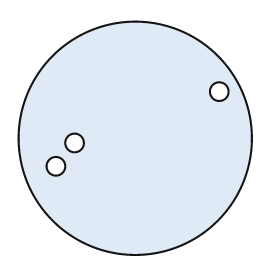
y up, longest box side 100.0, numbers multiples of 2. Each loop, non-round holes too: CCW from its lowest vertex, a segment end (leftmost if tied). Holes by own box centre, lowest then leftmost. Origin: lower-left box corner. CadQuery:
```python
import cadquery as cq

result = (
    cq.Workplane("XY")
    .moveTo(50.0, 50.0)
    .circle(50.0)
    .moveTo(16.0, 38.0)
    .circle(4.0)
    .moveTo(24.0, 48.0)
    .circle(4.0)
    .moveTo(86.0, 70.0)
    .circle(4.0)
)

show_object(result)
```